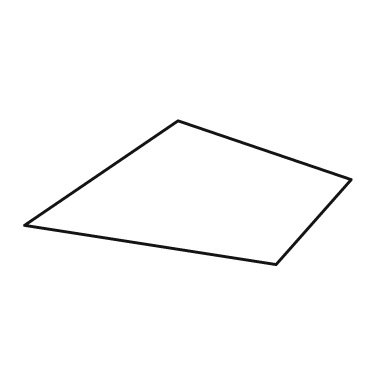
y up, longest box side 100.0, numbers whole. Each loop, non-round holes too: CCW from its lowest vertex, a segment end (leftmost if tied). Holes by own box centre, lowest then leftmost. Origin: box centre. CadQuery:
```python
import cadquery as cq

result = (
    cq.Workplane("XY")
    .moveTo(27.0, -22.0)
    .lineTo(50.0, 4.0)
    .lineTo(-3.0, 22.0)
    .lineTo(-50.0, -10.0)
    .close()
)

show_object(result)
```